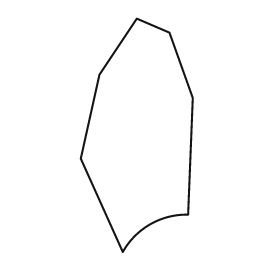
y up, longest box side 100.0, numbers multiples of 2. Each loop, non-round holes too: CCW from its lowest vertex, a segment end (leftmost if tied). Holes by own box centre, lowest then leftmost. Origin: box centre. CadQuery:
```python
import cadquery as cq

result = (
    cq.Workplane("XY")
    .moveTo(-6.0, -50.0)
    .threePointArc((6.0, -38.0), (22.0, -34.0))
    .lineTo(24.0, 16.0)
    .lineTo(14.0, 44.0)
    .lineTo(0.0, 50.0)
    .lineTo(-16.0, 26.0)
    .lineTo(-24.0, -10.0)
    .close()
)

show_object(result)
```